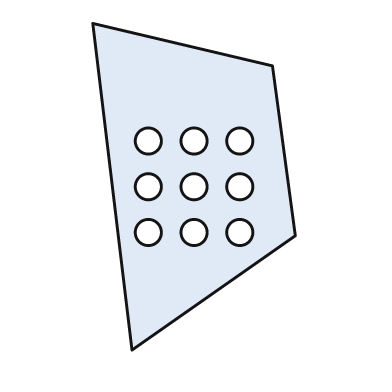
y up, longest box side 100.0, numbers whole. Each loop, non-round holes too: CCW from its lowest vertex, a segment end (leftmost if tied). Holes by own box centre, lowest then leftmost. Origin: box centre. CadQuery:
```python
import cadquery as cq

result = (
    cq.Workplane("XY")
    .moveTo(-19.0, -50.0)
    .lineTo(31.0, -15.0)
    .lineTo(24.0, 37.0)
    .lineTo(-31.0, 50.0)
    .close()
    .moveTo(-14.0, -14.0)
    .circle(4.0)
    .moveTo(0.0, -14.0)
    .circle(4.0)
    .moveTo(14.0, -14.0)
    .circle(4.0)
    .moveTo(-14.0, 0.0)
    .circle(4.0)
    .moveTo(0.0, 0.0)
    .circle(4.0)
    .moveTo(14.0, 0.0)
    .circle(4.0)
    .moveTo(-14.0, 14.0)
    .circle(4.0)
    .moveTo(0.0, 14.0)
    .circle(4.0)
    .moveTo(14.0, 14.0)
    .circle(4.0)
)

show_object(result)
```